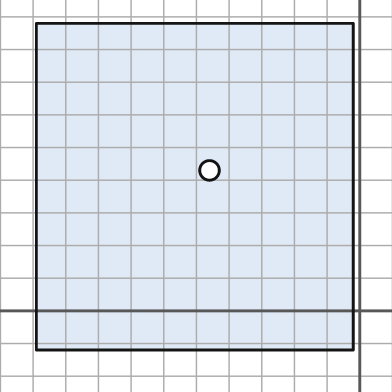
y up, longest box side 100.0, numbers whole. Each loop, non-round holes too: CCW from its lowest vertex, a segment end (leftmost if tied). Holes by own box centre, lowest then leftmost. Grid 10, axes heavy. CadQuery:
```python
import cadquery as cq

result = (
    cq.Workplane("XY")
    .moveTo(-99.0, -12.0)
    .lineTo(-2.0, -12.0)
    .lineTo(-2.0, 88.0)
    .lineTo(-99.0, 88.0)
    .close()
    .moveTo(-46.0, 43.0)
    .circle(3.0)
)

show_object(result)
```